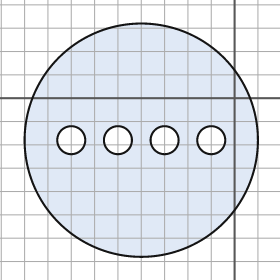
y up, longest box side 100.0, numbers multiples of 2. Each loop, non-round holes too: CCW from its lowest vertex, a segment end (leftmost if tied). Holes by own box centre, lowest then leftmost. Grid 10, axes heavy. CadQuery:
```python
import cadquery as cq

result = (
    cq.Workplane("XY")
    .moveTo(-40.0, -18.0)
    .circle(50.0)
    .moveTo(-70.0, -18.0)
    .circle(6.0)
    .moveTo(-50.0, -18.0)
    .circle(6.0)
    .moveTo(-30.0, -18.0)
    .circle(6.0)
    .moveTo(-10.0, -18.0)
    .circle(6.0)
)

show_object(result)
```